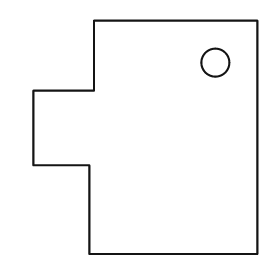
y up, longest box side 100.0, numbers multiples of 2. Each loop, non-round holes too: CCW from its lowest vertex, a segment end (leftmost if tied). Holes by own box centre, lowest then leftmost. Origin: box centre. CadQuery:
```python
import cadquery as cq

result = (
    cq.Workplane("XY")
    .moveTo(-24.0, -50.0)
    .lineTo(48.0, -50.0)
    .lineTo(48.0, 50.0)
    .lineTo(-22.0, 50.0)
    .lineTo(-22.0, 20.0)
    .lineTo(-48.0, 20.0)
    .lineTo(-48.0, -12.0)
    .lineTo(-24.0, -12.0)
    .close()
    .moveTo(30.0, 32.0)
    .circle(6.0)
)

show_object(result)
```